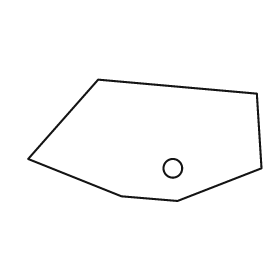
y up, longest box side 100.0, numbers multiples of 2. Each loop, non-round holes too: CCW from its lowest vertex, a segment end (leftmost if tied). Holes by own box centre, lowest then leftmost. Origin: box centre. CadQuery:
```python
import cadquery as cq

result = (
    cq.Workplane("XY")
    .moveTo(14.0, -26.0)
    .lineTo(50.0, -12.0)
    .lineTo(48.0, 20.0)
    .lineTo(-20.0, 26.0)
    .lineTo(-50.0, -8.0)
    .lineTo(-10.0, -24.0)
    .close()
    .moveTo(12.0, -12.0)
    .circle(4.0)
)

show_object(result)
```